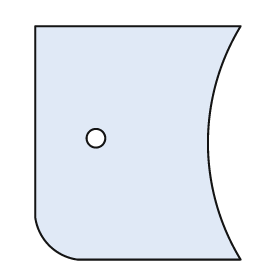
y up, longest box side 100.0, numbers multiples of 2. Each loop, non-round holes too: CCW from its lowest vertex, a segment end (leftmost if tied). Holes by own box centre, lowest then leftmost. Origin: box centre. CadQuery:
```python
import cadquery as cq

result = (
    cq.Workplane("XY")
    .moveTo(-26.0, -50.0)
    .lineTo(44.0, -50.0)
    .threePointArc((30.0, 0.0), (44.0, 50.0))
    .lineTo(-44.0, 50.0)
    .lineTo(-44.0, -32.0)
    .threePointArc((-38.0, -44.0), (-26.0, -50.0))
    .close()
    .moveTo(-18.0, 2.0)
    .circle(4.0)
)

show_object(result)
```